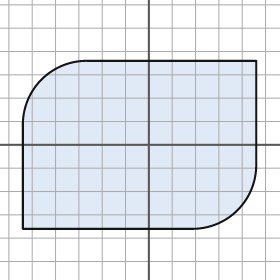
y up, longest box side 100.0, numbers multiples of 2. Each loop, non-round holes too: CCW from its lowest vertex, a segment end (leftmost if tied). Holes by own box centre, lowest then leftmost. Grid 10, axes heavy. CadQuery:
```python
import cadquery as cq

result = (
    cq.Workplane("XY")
    .moveTo(-54.0, -36.0)
    .lineTo(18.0, -36.0)
    .threePointArc((38.0, -28.0), (46.0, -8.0))
    .lineTo(46.0, 36.0)
    .lineTo(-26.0, 36.0)
    .threePointArc((-46.0, 28.0), (-54.0, 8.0))
    .close()
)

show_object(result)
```